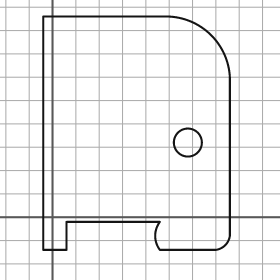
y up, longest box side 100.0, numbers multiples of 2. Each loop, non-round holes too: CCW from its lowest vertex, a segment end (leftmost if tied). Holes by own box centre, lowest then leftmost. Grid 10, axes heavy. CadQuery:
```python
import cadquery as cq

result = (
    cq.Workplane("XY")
    .moveTo(-4.0, -14.0)
    .lineTo(6.0, -14.0)
    .lineTo(6.0, -2.0)
    .lineTo(46.0, -2.0)
    .threePointArc((44.0, -8.0), (46.0, -14.0))
    .lineTo(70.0, -14.0)
    .threePointArc((74.0, -12.0), (76.0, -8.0))
    .lineTo(76.0, 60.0)
    .threePointArc((68.0, 78.0), (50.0, 86.0))
    .lineTo(-4.0, 86.0)
    .close()
    .moveTo(58.0, 32.0)
    .circle(6.0)
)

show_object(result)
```